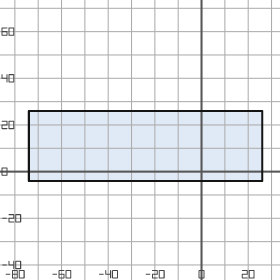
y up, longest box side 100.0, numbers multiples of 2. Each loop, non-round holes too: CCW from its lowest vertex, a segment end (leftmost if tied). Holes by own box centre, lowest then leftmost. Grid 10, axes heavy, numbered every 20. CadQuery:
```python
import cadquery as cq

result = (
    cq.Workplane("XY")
    .moveTo(-74.0, -4.0)
    .lineTo(26.0, -4.0)
    .lineTo(26.0, 26.0)
    .lineTo(-74.0, 26.0)
    .close()
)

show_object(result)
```